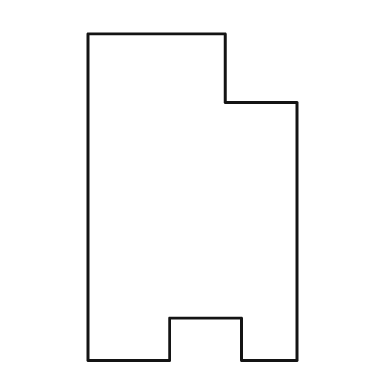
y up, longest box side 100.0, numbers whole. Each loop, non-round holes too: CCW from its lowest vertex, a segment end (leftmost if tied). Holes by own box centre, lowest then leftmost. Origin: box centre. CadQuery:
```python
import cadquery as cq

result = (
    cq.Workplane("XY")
    .moveTo(-32.0, -50.0)
    .lineTo(-7.0, -50.0)
    .lineTo(-7.0, -37.0)
    .lineTo(15.0, -37.0)
    .lineTo(15.0, -50.0)
    .lineTo(32.0, -50.0)
    .lineTo(32.0, 29.0)
    .lineTo(10.0, 29.0)
    .lineTo(10.0, 50.0)
    .lineTo(-32.0, 50.0)
    .close()
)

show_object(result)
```